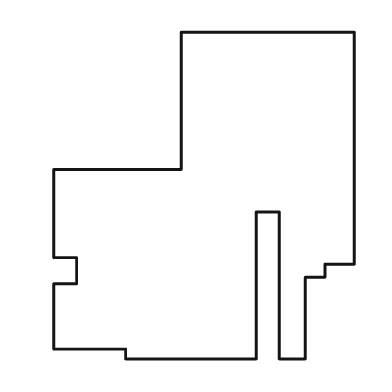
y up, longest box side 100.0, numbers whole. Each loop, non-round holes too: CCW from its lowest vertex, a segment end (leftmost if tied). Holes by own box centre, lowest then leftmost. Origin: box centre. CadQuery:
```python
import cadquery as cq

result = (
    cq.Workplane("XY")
    .moveTo(-24.0, -50.0)
    .lineTo(16.0, -50.0)
    .lineTo(16.0, -5.0)
    .lineTo(23.0, -5.0)
    .lineTo(23.0, -50.0)
    .lineTo(31.0, -50.0)
    .lineTo(31.0, -25.0)
    .lineTo(37.0, -25.0)
    .lineTo(37.0, -21.0)
    .lineTo(46.0, -21.0)
    .lineTo(46.0, 50.0)
    .lineTo(-7.0, 50.0)
    .lineTo(-7.0, 8.0)
    .lineTo(-46.0, 8.0)
    .lineTo(-46.0, -19.0)
    .lineTo(-39.0, -19.0)
    .lineTo(-39.0, -27.0)
    .lineTo(-46.0, -27.0)
    .lineTo(-46.0, -47.0)
    .lineTo(-24.0, -47.0)
    .close()
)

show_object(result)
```